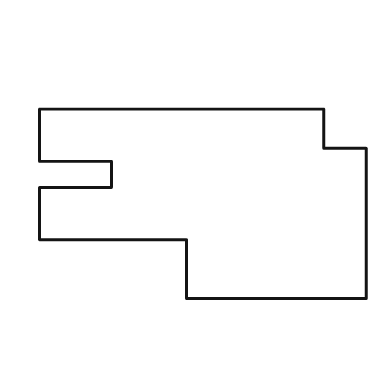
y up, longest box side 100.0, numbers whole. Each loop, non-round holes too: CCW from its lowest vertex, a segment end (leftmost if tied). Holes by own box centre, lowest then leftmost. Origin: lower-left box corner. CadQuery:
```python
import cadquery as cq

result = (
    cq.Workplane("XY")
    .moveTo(45.0, 0.0)
    .lineTo(100.0, 0.0)
    .lineTo(100.0, 46.0)
    .lineTo(87.0, 46.0)
    .lineTo(87.0, 58.0)
    .lineTo(0.0, 58.0)
    .lineTo(0.0, 42.0)
    .lineTo(22.0, 42.0)
    .lineTo(22.0, 34.0)
    .lineTo(0.0, 34.0)
    .lineTo(0.0, 18.0)
    .lineTo(45.0, 18.0)
    .close()
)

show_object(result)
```